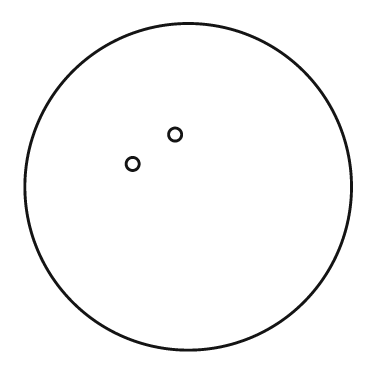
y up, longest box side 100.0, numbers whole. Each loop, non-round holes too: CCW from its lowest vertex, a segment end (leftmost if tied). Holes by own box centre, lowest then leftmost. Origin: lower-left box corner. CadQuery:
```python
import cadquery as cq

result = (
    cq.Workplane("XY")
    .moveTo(50.0, 50.0)
    .circle(50.0)
    .moveTo(33.0, 57.0)
    .circle(2.0)
    .moveTo(46.0, 66.0)
    .circle(2.0)
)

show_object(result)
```